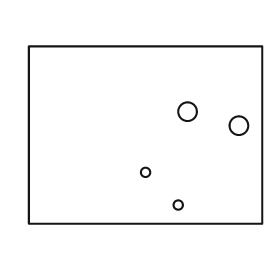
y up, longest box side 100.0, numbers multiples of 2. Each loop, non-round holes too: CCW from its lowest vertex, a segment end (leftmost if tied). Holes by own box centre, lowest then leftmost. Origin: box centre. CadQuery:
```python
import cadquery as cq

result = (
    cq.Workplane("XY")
    .moveTo(-50.0, -38.0)
    .lineTo(50.0, -38.0)
    .lineTo(50.0, 38.0)
    .lineTo(-50.0, 38.0)
    .close()
    .moveTo(14.0, -30.0)
    .circle(2.0)
    .moveTo(0.0, -16.0)
    .circle(2.0)
    .moveTo(40.0, 4.0)
    .circle(4.0)
    .moveTo(18.0, 10.0)
    .circle(4.0)
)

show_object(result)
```